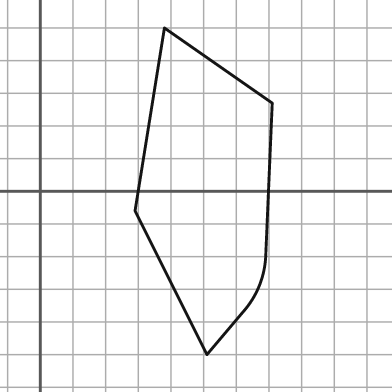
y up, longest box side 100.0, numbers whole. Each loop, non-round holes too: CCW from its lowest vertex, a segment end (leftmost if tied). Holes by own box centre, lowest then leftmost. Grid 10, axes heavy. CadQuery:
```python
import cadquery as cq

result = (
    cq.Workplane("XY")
    .moveTo(51.0, -50.0)
    .lineTo(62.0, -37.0)
    .threePointArc((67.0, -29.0), (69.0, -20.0))
    .lineTo(71.0, 27.0)
    .lineTo(38.0, 50.0)
    .lineTo(29.0, -6.0)
    .close()
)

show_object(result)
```